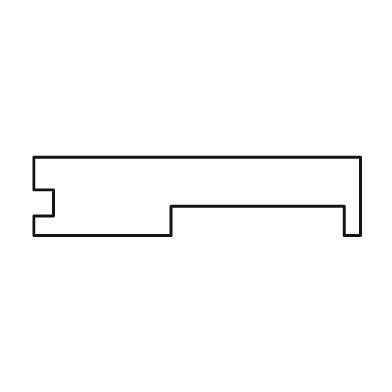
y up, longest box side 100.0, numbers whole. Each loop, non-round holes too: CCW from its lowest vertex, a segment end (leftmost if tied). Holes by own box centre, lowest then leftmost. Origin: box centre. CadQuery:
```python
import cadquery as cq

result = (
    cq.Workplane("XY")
    .moveTo(-50.0, -12.0)
    .lineTo(-8.0, -12.0)
    .lineTo(-8.0, -3.0)
    .lineTo(45.0, -3.0)
    .lineTo(45.0, -12.0)
    .lineTo(50.0, -12.0)
    .lineTo(50.0, 12.0)
    .lineTo(-50.0, 12.0)
    .lineTo(-50.0, 2.0)
    .lineTo(-44.0, 2.0)
    .lineTo(-44.0, -6.0)
    .lineTo(-50.0, -6.0)
    .close()
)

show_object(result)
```